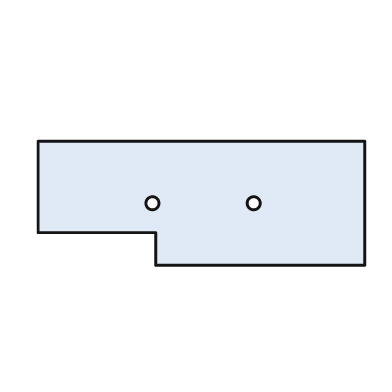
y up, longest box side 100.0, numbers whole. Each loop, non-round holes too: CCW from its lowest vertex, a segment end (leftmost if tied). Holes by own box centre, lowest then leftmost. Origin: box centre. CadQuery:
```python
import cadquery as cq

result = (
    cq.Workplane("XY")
    .moveTo(-14.0, -19.0)
    .lineTo(50.0, -19.0)
    .lineTo(50.0, 19.0)
    .lineTo(-50.0, 19.0)
    .lineTo(-50.0, -9.0)
    .lineTo(-14.0, -9.0)
    .close()
    .moveTo(-15.0, 0.0)
    .circle(2.0)
    .moveTo(16.0, 0.0)
    .circle(2.0)
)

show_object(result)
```